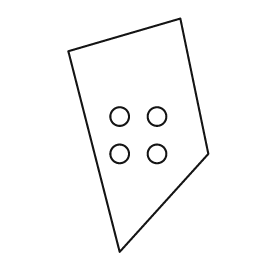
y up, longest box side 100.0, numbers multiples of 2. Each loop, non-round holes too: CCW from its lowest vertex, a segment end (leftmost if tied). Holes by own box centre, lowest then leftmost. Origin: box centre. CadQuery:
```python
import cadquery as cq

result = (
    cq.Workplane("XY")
    .moveTo(-8.0, -50.0)
    .lineTo(30.0, -8.0)
    .lineTo(18.0, 50.0)
    .lineTo(-30.0, 36.0)
    .close()
    .moveTo(-8.0, -8.0)
    .circle(4.0)
    .moveTo(8.0, -8.0)
    .circle(4.0)
    .moveTo(-8.0, 8.0)
    .circle(4.0)
    .moveTo(8.0, 8.0)
    .circle(4.0)
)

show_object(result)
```